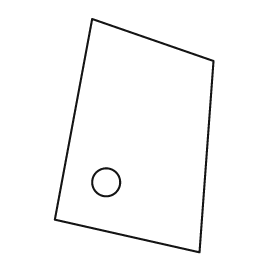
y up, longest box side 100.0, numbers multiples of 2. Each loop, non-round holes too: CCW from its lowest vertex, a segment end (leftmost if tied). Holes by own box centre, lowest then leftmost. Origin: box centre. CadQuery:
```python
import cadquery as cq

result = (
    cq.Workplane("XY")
    .moveTo(28.0, -50.0)
    .lineTo(34.0, 32.0)
    .lineTo(-18.0, 50.0)
    .lineTo(-34.0, -36.0)
    .close()
    .moveTo(-12.0, -20.0)
    .circle(6.0)
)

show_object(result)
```